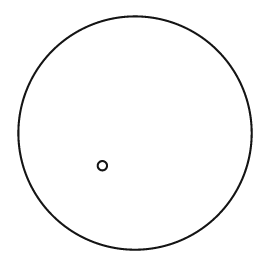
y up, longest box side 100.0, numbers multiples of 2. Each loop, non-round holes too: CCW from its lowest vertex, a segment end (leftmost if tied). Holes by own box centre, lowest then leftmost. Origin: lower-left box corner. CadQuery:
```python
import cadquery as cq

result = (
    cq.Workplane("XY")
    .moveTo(50.0, 50.0)
    .circle(50.0)
    .moveTo(36.0, 36.0)
    .circle(2.0)
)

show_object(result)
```